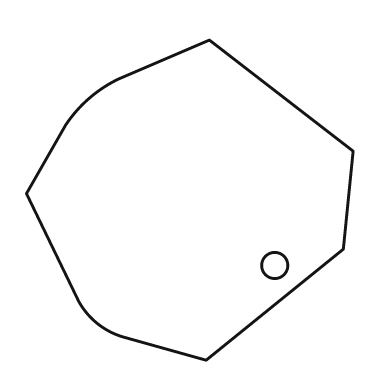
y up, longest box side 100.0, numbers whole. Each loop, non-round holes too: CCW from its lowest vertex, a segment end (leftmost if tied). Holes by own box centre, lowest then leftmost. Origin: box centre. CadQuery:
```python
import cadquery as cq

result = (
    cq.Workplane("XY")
    .moveTo(5.0, -49.0)
    .lineTo(47.0, -15.0)
    .lineTo(50.0, 15.0)
    .lineTo(6.0, 49.0)
    .lineTo(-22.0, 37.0)
    .threePointArc((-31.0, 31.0), (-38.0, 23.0))
    .lineTo(-50.0, 2.0)
    .lineTo(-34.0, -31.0)
    .threePointArc((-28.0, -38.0), (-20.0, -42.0))
    .close()
    .moveTo(26.0, -20.0)
    .circle(4.0)
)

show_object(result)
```